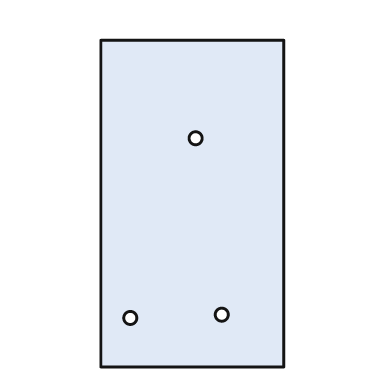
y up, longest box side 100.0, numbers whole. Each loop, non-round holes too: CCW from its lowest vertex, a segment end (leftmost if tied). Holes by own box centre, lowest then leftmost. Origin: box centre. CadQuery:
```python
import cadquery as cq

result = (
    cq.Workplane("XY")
    .moveTo(-28.0, -50.0)
    .lineTo(28.0, -50.0)
    .lineTo(28.0, 50.0)
    .lineTo(-28.0, 50.0)
    .close()
    .moveTo(-19.0, -35.0)
    .circle(2.0)
    .moveTo(9.0, -34.0)
    .circle(2.0)
    .moveTo(1.0, 20.0)
    .circle(2.0)
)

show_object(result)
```